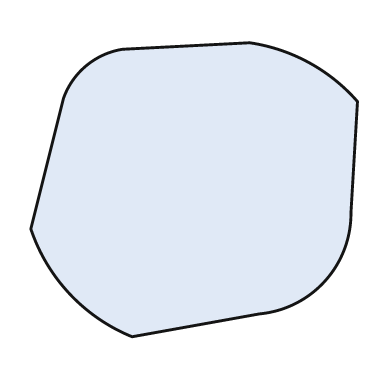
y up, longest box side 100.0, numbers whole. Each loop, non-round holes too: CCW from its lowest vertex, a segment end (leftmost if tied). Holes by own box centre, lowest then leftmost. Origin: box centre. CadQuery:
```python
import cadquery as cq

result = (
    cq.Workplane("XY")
    .moveTo(-19.0, -45.0)
    .lineTo(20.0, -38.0)
    .threePointArc((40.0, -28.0), (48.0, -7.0))
    .lineTo(50.0, 27.0)
    .threePointArc((35.0, 39.0), (17.0, 45.0))
    .lineTo(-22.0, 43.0)
    .threePointArc((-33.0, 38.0), (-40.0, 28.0))
    .lineTo(-50.0, -12.0)
    .threePointArc((-38.0, -32.0), (-19.0, -45.0))
    .close()
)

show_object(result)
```